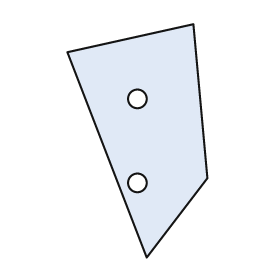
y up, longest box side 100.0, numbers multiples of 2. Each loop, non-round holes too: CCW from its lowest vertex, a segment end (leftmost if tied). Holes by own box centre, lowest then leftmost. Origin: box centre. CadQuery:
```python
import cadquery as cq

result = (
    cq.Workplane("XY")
    .moveTo(4.0, -50.0)
    .lineTo(30.0, -16.0)
    .lineTo(24.0, 50.0)
    .lineTo(-30.0, 38.0)
    .close()
    .moveTo(0.0, -18.0)
    .circle(4.0)
    .moveTo(0.0, 18.0)
    .circle(4.0)
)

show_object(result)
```